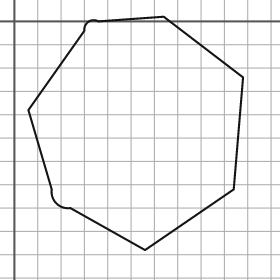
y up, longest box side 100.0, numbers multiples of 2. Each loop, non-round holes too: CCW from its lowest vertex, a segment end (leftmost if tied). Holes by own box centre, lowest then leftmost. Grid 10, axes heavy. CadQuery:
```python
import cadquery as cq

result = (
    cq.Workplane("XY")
    .moveTo(56.0, -98.0)
    .lineTo(94.0, -72.0)
    .lineTo(98.0, -24.0)
    .lineTo(64.0, 2.0)
    .lineTo(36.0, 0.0)
    .threePointArc((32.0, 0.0), (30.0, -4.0))
    .lineTo(6.0, -38.0)
    .lineTo(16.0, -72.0)
    .threePointArc((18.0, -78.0), (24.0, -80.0))
    .close()
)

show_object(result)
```